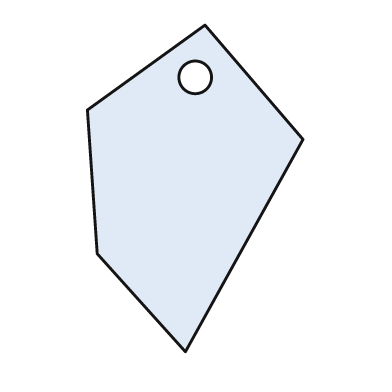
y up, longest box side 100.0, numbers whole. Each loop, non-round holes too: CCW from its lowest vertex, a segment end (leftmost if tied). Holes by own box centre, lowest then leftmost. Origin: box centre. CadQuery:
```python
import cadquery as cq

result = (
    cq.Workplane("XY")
    .moveTo(-3.0, -50.0)
    .lineTo(33.0, 15.0)
    .lineTo(3.0, 50.0)
    .lineTo(-33.0, 24.0)
    .lineTo(-30.0, -20.0)
    .close()
    .moveTo(0.0, 34.0)
    .circle(5.0)
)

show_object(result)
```